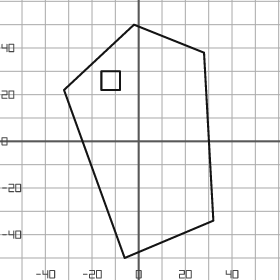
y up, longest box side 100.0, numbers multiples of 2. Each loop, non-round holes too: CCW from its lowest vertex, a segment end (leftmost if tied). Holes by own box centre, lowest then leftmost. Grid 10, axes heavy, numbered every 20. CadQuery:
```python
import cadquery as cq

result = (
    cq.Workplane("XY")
    .moveTo(-6.0, -50.0)
    .lineTo(32.0, -34.0)
    .lineTo(28.0, 38.0)
    .lineTo(-2.0, 50.0)
    .lineTo(-32.0, 22.0)
    .close()
    .moveTo(-16.0, 22.0)
    .lineTo(-8.0, 22.0)
    .lineTo(-8.0, 30.0)
    .lineTo(-16.0, 30.0)
    .close()
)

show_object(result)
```